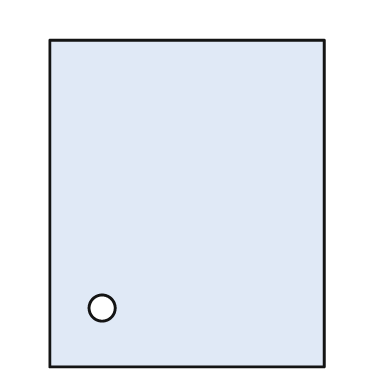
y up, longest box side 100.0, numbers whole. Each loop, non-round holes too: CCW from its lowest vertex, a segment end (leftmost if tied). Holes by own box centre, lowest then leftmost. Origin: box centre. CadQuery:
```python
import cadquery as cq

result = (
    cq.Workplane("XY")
    .moveTo(-42.0, -50.0)
    .lineTo(42.0, -50.0)
    .lineTo(42.0, 50.0)
    .lineTo(-42.0, 50.0)
    .close()
    .moveTo(-26.0, -32.0)
    .circle(4.0)
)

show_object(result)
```